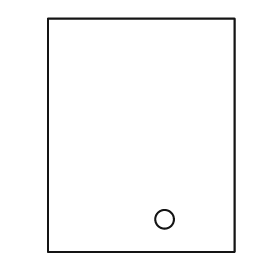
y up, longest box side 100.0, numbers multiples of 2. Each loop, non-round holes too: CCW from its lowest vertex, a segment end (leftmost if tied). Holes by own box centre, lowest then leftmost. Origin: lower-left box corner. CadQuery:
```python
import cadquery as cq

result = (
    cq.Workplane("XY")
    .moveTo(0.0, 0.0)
    .lineTo(80.0, 0.0)
    .lineTo(80.0, 100.0)
    .lineTo(0.0, 100.0)
    .close()
    .moveTo(50.0, 14.0)
    .circle(4.0)
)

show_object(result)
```